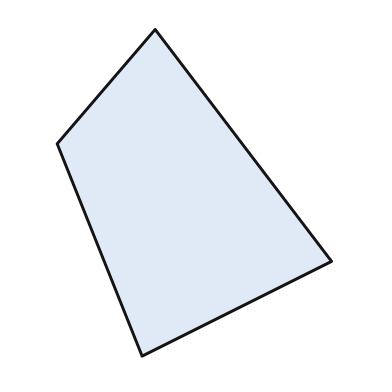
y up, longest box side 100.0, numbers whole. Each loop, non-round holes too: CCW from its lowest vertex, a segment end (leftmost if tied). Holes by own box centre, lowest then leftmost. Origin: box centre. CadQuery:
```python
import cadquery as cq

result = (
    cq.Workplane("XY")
    .moveTo(-16.0, -50.0)
    .lineTo(42.0, -21.0)
    .lineTo(-12.0, 50.0)
    .lineTo(-42.0, 15.0)
    .close()
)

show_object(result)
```